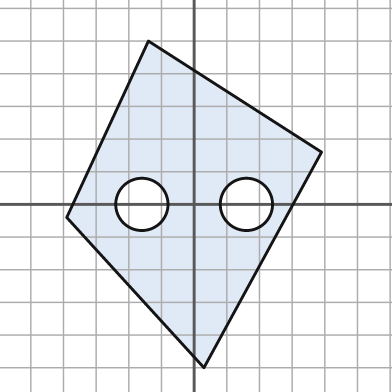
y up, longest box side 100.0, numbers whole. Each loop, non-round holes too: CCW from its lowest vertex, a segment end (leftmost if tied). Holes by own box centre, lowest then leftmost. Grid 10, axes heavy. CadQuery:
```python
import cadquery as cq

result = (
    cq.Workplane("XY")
    .moveTo(3.0, -50.0)
    .lineTo(39.0, 16.0)
    .lineTo(-14.0, 50.0)
    .lineTo(-39.0, -4.0)
    .close()
    .moveTo(-16.0, 0.0)
    .circle(8.0)
    .moveTo(16.0, 0.0)
    .circle(8.0)
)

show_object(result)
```